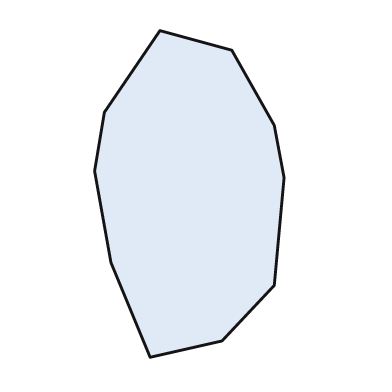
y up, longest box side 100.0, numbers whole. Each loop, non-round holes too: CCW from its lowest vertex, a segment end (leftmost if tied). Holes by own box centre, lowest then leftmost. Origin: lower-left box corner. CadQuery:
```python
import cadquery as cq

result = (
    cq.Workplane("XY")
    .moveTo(17.0, 0.0)
    .lineTo(39.0, 5.0)
    .lineTo(55.0, 22.0)
    .lineTo(58.0, 55.0)
    .lineTo(55.0, 71.0)
    .lineTo(42.0, 94.0)
    .lineTo(20.0, 100.0)
    .lineTo(3.0, 75.0)
    .lineTo(0.0, 57.0)
    .lineTo(5.0, 29.0)
    .close()
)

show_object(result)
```